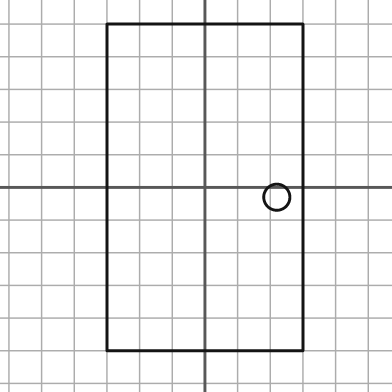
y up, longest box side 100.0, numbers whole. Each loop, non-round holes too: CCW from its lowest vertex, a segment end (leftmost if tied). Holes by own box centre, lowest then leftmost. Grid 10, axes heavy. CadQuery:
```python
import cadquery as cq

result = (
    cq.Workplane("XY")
    .moveTo(-30.0, -50.0)
    .lineTo(30.0, -50.0)
    .lineTo(30.0, 50.0)
    .lineTo(-30.0, 50.0)
    .close()
    .moveTo(22.0, -3.0)
    .circle(4.0)
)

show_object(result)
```